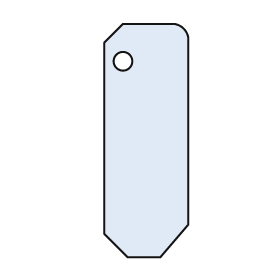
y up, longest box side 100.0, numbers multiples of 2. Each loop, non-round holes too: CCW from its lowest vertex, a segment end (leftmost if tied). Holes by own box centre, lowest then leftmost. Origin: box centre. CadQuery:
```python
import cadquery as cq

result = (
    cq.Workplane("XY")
    .moveTo(-8.0, -50.0)
    .lineTo(6.0, -50.0)
    .lineTo(18.0, -36.0)
    .lineTo(18.0, 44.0)
    .threePointArc((16.0, 48.0), (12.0, 50.0))
    .lineTo(-10.0, 50.0)
    .lineTo(-18.0, 42.0)
    .lineTo(-18.0, -40.0)
    .close()
    .moveTo(-10.0, 34.0)
    .circle(4.0)
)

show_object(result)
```